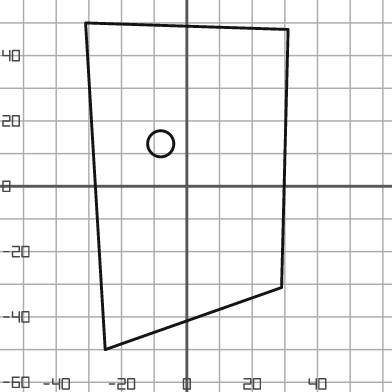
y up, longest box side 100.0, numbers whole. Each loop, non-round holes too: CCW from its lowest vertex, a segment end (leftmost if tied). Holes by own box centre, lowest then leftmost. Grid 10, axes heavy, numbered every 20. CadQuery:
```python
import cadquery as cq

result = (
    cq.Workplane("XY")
    .moveTo(-25.0, -50.0)
    .lineTo(29.0, -31.0)
    .lineTo(31.0, 48.0)
    .lineTo(-31.0, 50.0)
    .close()
    .moveTo(-8.0, 13.0)
    .circle(4.0)
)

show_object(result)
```